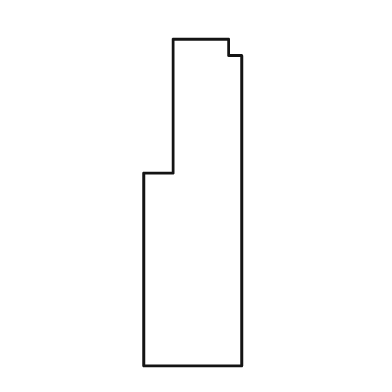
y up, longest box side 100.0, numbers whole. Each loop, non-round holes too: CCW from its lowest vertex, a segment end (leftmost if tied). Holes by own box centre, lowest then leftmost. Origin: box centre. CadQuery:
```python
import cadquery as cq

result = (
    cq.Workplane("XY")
    .moveTo(-15.0, -50.0)
    .lineTo(15.0, -50.0)
    .lineTo(15.0, 45.0)
    .lineTo(11.0, 45.0)
    .lineTo(11.0, 50.0)
    .lineTo(-6.0, 50.0)
    .lineTo(-6.0, 9.0)
    .lineTo(-15.0, 9.0)
    .close()
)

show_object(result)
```